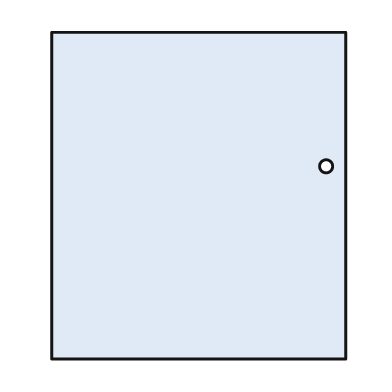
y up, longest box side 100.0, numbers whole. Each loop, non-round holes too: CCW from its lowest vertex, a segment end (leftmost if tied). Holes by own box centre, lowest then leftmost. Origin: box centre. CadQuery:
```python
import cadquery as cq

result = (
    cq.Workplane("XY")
    .moveTo(-45.0, -50.0)
    .lineTo(45.0, -50.0)
    .lineTo(45.0, 50.0)
    .lineTo(-45.0, 50.0)
    .close()
    .moveTo(39.0, 9.0)
    .circle(2.0)
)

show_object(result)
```